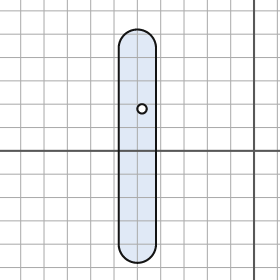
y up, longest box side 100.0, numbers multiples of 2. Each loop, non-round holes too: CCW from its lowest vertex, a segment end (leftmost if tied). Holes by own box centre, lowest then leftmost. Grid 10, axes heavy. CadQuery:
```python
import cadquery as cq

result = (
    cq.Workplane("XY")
    .moveTo(-58.0, -40.0)
    .threePointArc((-50.0, -48.0), (-42.0, -40.0))
    .lineTo(-42.0, 44.0)
    .threePointArc((-50.0, 52.0), (-58.0, 44.0))
    .close()
    .moveTo(-48.0, 18.0)
    .circle(2.0)
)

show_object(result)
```